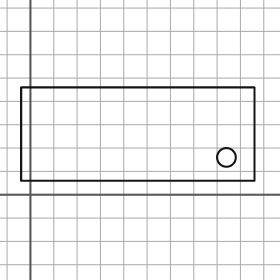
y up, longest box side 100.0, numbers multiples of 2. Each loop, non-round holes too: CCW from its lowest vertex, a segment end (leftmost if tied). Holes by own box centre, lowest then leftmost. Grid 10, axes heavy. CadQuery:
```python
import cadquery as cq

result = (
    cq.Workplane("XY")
    .moveTo(-4.0, 6.0)
    .lineTo(96.0, 6.0)
    .lineTo(96.0, 46.0)
    .lineTo(-4.0, 46.0)
    .close()
    .moveTo(84.0, 16.0)
    .circle(4.0)
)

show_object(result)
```